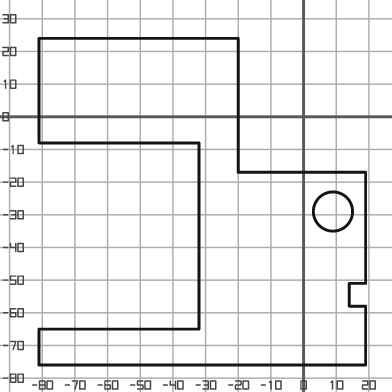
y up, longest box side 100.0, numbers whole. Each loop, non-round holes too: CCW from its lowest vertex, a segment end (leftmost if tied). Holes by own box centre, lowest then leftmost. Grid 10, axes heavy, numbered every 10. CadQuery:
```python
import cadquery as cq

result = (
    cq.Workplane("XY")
    .moveTo(-81.0, -76.0)
    .lineTo(19.0, -76.0)
    .lineTo(19.0, -58.0)
    .lineTo(14.0, -58.0)
    .lineTo(14.0, -51.0)
    .lineTo(19.0, -51.0)
    .lineTo(19.0, -17.0)
    .lineTo(-20.0, -17.0)
    .lineTo(-20.0, 24.0)
    .lineTo(-81.0, 24.0)
    .lineTo(-81.0, -8.0)
    .lineTo(-32.0, -8.0)
    .lineTo(-32.0, -65.0)
    .lineTo(-81.0, -65.0)
    .close()
    .moveTo(9.0, -29.0)
    .circle(6.0)
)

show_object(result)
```